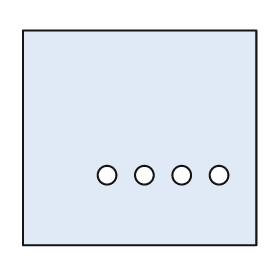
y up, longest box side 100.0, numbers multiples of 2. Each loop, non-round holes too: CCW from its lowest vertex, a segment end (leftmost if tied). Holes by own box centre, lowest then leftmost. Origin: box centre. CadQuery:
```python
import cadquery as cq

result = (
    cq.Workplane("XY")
    .moveTo(-50.0, -46.0)
    .lineTo(50.0, -46.0)
    .lineTo(50.0, 46.0)
    .lineTo(-50.0, 46.0)
    .close()
    .moveTo(-14.0, -16.0)
    .circle(4.0)
    .moveTo(2.0, -16.0)
    .circle(4.0)
    .moveTo(18.0, -16.0)
    .circle(4.0)
    .moveTo(34.0, -16.0)
    .circle(4.0)
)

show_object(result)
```